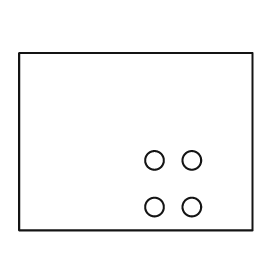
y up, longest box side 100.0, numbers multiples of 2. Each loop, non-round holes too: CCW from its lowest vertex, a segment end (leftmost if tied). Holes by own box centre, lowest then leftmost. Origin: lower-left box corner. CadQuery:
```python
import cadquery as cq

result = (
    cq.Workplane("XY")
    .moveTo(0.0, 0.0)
    .lineTo(100.0, 0.0)
    .lineTo(100.0, 76.0)
    .lineTo(0.0, 76.0)
    .close()
    .moveTo(58.0, 10.0)
    .circle(4.0)
    .moveTo(74.0, 10.0)
    .circle(4.0)
    .moveTo(58.0, 30.0)
    .circle(4.0)
    .moveTo(74.0, 30.0)
    .circle(4.0)
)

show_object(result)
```